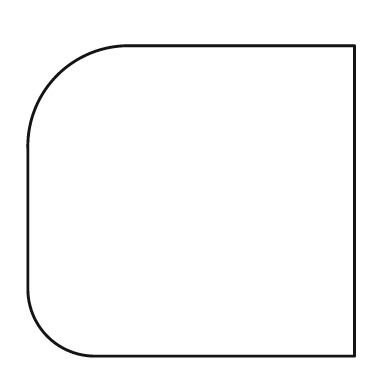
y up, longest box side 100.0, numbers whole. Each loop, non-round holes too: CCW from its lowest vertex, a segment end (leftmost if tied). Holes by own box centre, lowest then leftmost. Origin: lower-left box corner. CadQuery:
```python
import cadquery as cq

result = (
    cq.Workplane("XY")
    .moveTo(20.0, 0.0)
    .lineTo(100.0, 0.0)
    .lineTo(100.0, 95.0)
    .lineTo(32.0, 95.0)
    .threePointArc((9.0, 86.0), (0.0, 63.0))
    .lineTo(0.0, 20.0)
    .threePointArc((6.0, 6.0), (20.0, 0.0))
    .close()
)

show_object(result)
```